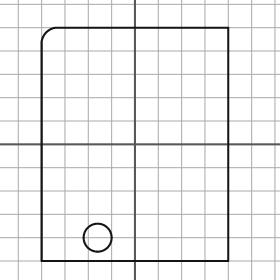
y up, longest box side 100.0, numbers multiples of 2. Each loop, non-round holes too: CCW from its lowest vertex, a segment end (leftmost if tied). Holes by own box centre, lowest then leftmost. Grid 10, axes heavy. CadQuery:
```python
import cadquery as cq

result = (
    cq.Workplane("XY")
    .moveTo(-40.0, -50.0)
    .lineTo(40.0, -50.0)
    .lineTo(40.0, 50.0)
    .lineTo(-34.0, 50.0)
    .threePointArc((-38.0, 48.0), (-40.0, 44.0))
    .close()
    .moveTo(-16.0, -40.0)
    .circle(6.0)
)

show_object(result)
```